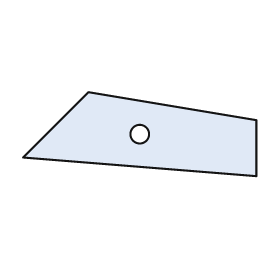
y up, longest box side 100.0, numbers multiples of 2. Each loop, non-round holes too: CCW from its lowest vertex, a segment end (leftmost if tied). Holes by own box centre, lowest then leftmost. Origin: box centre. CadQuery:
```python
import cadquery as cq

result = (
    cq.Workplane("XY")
    .moveTo(50.0, -18.0)
    .lineTo(50.0, 6.0)
    .lineTo(-22.0, 18.0)
    .lineTo(-50.0, -10.0)
    .close()
    .moveTo(0.0, 0.0)
    .circle(4.0)
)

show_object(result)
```